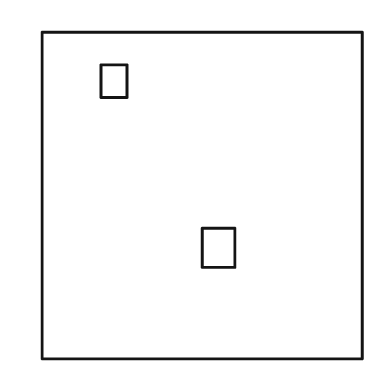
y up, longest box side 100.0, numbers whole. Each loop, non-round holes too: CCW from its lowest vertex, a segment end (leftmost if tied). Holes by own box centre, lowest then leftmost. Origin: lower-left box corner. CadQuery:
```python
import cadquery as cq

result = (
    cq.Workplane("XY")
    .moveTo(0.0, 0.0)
    .lineTo(98.0, 0.0)
    .lineTo(98.0, 100.0)
    .lineTo(0.0, 100.0)
    .close()
    .moveTo(49.0, 28.0)
    .lineTo(59.0, 28.0)
    .lineTo(59.0, 40.0)
    .lineTo(49.0, 40.0)
    .close()
    .moveTo(18.0, 80.0)
    .lineTo(26.0, 80.0)
    .lineTo(26.0, 90.0)
    .lineTo(18.0, 90.0)
    .close()
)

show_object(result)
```